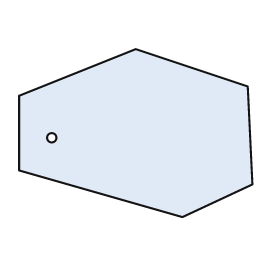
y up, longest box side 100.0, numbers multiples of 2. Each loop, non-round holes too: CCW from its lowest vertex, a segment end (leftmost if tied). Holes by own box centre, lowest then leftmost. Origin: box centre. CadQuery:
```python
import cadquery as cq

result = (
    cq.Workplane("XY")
    .moveTo(20.0, -36.0)
    .lineTo(50.0, -22.0)
    .lineTo(48.0, 20.0)
    .lineTo(0.0, 36.0)
    .lineTo(-50.0, 16.0)
    .lineTo(-50.0, -16.0)
    .close()
    .moveTo(-36.0, -2.0)
    .circle(2.0)
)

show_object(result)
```